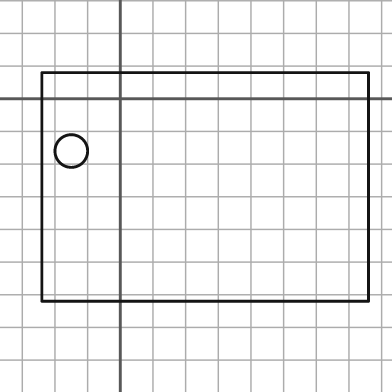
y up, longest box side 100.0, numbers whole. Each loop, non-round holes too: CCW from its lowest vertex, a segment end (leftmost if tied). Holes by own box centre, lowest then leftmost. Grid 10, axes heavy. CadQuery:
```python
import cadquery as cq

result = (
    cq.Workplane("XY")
    .moveTo(-24.0, -62.0)
    .lineTo(76.0, -62.0)
    .lineTo(76.0, 8.0)
    .lineTo(-24.0, 8.0)
    .close()
    .moveTo(-15.0, -16.0)
    .circle(5.0)
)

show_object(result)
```